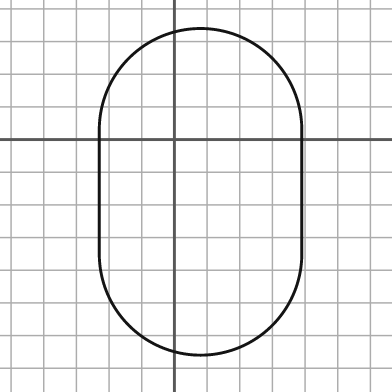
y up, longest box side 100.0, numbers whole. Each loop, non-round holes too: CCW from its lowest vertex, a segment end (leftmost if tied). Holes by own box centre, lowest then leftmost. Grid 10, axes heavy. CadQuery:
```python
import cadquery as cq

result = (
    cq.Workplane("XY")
    .moveTo(-23.0, -35.0)
    .threePointArc((8.0, -66.0), (39.0, -35.0))
    .lineTo(39.0, 3.0)
    .threePointArc((8.0, 34.0), (-23.0, 3.0))
    .close()
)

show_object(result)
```